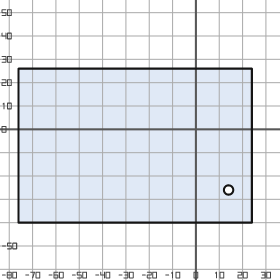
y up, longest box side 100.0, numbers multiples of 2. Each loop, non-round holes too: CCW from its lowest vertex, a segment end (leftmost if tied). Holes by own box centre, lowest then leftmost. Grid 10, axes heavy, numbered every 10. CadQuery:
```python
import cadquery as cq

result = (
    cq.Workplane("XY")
    .moveTo(-76.0, -40.0)
    .lineTo(24.0, -40.0)
    .lineTo(24.0, 26.0)
    .lineTo(-76.0, 26.0)
    .close()
    .moveTo(14.0, -26.0)
    .circle(2.0)
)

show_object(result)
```